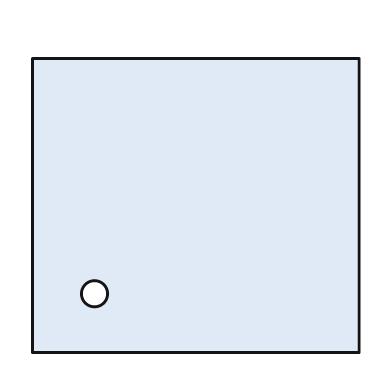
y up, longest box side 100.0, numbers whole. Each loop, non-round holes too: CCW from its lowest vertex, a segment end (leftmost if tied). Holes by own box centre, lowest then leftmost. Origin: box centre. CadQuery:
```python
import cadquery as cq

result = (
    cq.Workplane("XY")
    .moveTo(-50.0, -45.0)
    .lineTo(50.0, -45.0)
    .lineTo(50.0, 45.0)
    .lineTo(-50.0, 45.0)
    .close()
    .moveTo(-31.0, -27.0)
    .circle(4.0)
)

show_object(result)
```